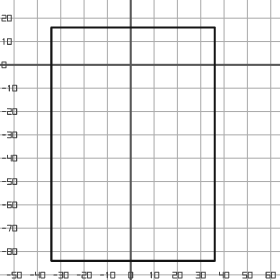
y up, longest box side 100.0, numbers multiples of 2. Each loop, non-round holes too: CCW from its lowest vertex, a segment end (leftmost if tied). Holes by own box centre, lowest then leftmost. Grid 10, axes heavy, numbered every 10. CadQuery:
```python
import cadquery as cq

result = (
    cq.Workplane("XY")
    .moveTo(-34.0, -84.0)
    .lineTo(36.0, -84.0)
    .lineTo(36.0, 16.0)
    .lineTo(-34.0, 16.0)
    .close()
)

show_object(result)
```